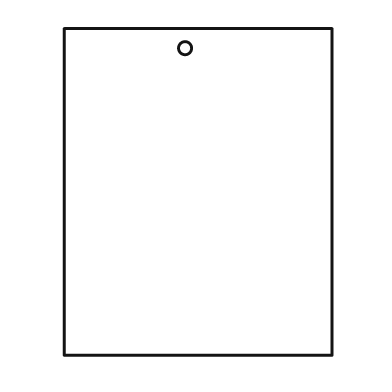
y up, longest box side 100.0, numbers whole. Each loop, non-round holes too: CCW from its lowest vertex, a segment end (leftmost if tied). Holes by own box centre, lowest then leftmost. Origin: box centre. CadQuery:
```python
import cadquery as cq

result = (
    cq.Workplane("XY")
    .moveTo(-41.0, -50.0)
    .lineTo(41.0, -50.0)
    .lineTo(41.0, 50.0)
    .lineTo(-41.0, 50.0)
    .close()
    .moveTo(-4.0, 44.0)
    .circle(2.0)
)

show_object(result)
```